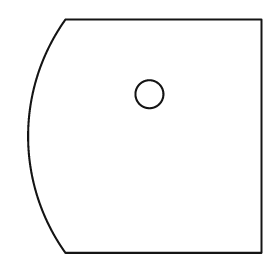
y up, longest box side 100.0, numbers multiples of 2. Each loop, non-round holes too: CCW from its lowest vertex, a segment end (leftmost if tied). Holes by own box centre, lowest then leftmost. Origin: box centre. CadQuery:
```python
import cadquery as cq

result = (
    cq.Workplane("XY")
    .moveTo(-34.0, -50.0)
    .lineTo(50.0, -50.0)
    .lineTo(50.0, 50.0)
    .lineTo(-34.0, 50.0)
    .threePointArc((-50.0, 0.0), (-34.0, -50.0))
    .close()
    .moveTo(2.0, 18.0)
    .circle(6.0)
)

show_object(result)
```